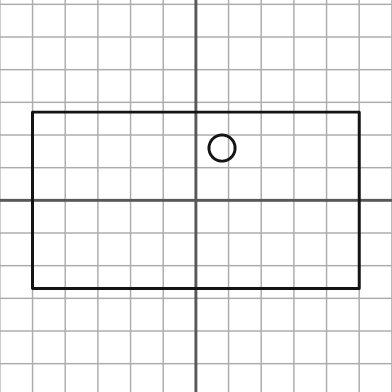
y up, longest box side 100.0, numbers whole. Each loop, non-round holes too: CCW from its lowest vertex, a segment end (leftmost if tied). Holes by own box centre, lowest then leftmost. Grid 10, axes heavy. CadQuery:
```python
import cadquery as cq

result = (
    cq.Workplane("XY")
    .moveTo(-50.0, -27.0)
    .lineTo(50.0, -27.0)
    .lineTo(50.0, 27.0)
    .lineTo(-50.0, 27.0)
    .close()
    .moveTo(8.0, 16.0)
    .circle(4.0)
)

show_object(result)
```